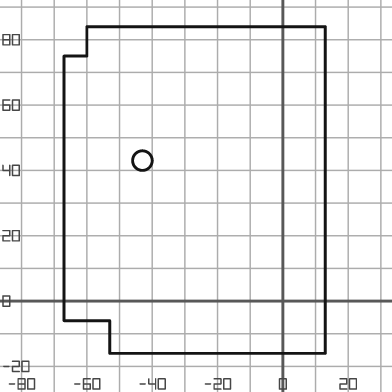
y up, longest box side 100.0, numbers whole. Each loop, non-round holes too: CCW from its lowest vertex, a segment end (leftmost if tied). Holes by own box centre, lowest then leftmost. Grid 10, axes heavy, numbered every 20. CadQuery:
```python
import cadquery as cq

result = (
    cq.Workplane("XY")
    .moveTo(-53.0, -16.0)
    .lineTo(13.0, -16.0)
    .lineTo(13.0, 84.0)
    .lineTo(-60.0, 84.0)
    .lineTo(-60.0, 75.0)
    .lineTo(-67.0, 75.0)
    .lineTo(-67.0, -6.0)
    .lineTo(-53.0, -6.0)
    .close()
    .moveTo(-43.0, 43.0)
    .circle(3.0)
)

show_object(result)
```